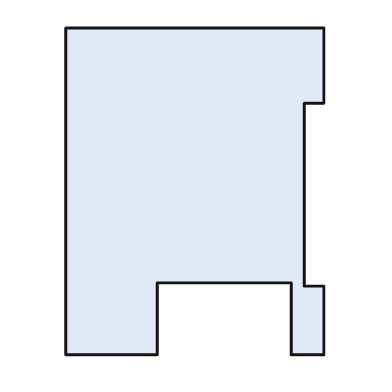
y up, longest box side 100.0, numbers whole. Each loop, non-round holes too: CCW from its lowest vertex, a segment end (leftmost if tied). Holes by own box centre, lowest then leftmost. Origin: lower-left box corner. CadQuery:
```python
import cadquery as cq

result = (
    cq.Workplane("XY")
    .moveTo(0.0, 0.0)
    .lineTo(28.0, 0.0)
    .lineTo(28.0, 22.0)
    .lineTo(69.0, 22.0)
    .lineTo(69.0, 0.0)
    .lineTo(79.0, 0.0)
    .lineTo(79.0, 21.0)
    .lineTo(73.0, 21.0)
    .lineTo(73.0, 77.0)
    .lineTo(79.0, 77.0)
    .lineTo(79.0, 100.0)
    .lineTo(0.0, 100.0)
    .close()
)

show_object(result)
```